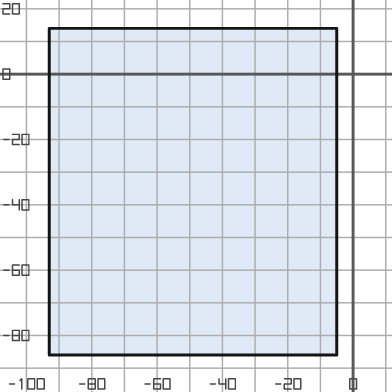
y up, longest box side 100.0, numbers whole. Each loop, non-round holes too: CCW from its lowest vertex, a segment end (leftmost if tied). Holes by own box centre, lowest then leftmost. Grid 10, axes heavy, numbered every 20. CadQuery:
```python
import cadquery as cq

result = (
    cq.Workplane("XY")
    .moveTo(-93.0, -86.0)
    .lineTo(-5.0, -86.0)
    .lineTo(-5.0, 14.0)
    .lineTo(-93.0, 14.0)
    .close()
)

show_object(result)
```